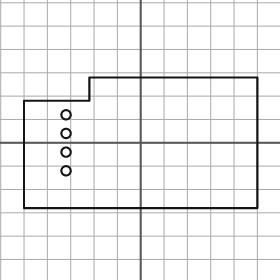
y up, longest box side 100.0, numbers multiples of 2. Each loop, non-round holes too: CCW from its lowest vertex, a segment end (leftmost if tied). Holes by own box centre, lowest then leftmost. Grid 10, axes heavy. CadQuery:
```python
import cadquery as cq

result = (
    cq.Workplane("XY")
    .moveTo(-50.0, -28.0)
    .lineTo(50.0, -28.0)
    .lineTo(50.0, 28.0)
    .lineTo(-22.0, 28.0)
    .lineTo(-22.0, 18.0)
    .lineTo(-50.0, 18.0)
    .close()
    .moveTo(-32.0, -12.0)
    .circle(2.0)
    .moveTo(-32.0, -4.0)
    .circle(2.0)
    .moveTo(-32.0, 4.0)
    .circle(2.0)
    .moveTo(-32.0, 12.0)
    .circle(2.0)
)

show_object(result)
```